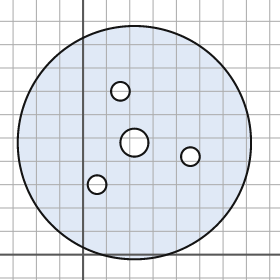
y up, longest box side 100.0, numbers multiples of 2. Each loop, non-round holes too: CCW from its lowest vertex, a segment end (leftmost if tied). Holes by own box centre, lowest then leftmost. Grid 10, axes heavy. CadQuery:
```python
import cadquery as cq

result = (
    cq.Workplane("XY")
    .moveTo(22.0, 48.0)
    .circle(50.0)
    .moveTo(6.0, 30.0)
    .circle(4.0)
    .moveTo(46.0, 42.0)
    .circle(4.0)
    .moveTo(22.0, 48.0)
    .circle(6.0)
    .moveTo(16.0, 70.0)
    .circle(4.0)
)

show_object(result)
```